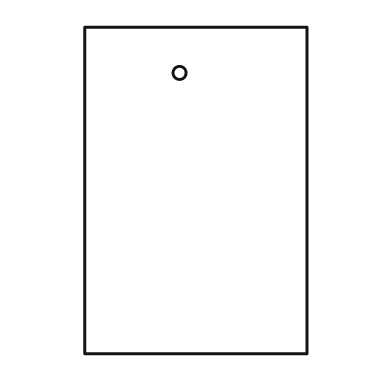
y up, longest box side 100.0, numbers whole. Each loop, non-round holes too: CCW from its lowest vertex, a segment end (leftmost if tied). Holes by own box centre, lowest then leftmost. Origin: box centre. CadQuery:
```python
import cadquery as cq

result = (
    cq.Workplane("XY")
    .moveTo(-34.0, -50.0)
    .lineTo(34.0, -50.0)
    .lineTo(34.0, 50.0)
    .lineTo(-34.0, 50.0)
    .close()
    .moveTo(-5.0, 36.0)
    .circle(2.0)
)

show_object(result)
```